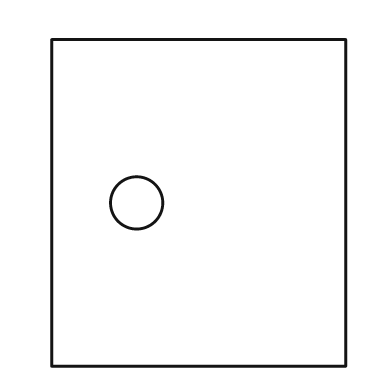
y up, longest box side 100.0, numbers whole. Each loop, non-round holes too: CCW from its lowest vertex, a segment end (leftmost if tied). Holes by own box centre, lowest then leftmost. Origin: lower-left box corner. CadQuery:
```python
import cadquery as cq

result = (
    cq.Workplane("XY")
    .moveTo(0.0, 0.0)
    .lineTo(90.0, 0.0)
    .lineTo(90.0, 100.0)
    .lineTo(0.0, 100.0)
    .close()
    .moveTo(26.0, 50.0)
    .circle(8.0)
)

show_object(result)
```